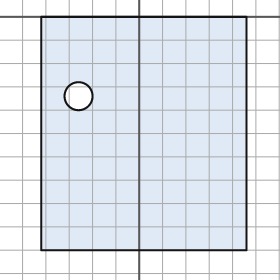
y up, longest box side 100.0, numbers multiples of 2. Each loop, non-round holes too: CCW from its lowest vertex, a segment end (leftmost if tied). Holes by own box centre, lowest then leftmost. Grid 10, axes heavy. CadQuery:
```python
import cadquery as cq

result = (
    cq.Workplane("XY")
    .moveTo(-42.0, -100.0)
    .lineTo(46.0, -100.0)
    .lineTo(46.0, 0.0)
    .lineTo(-42.0, 0.0)
    .close()
    .moveTo(-26.0, -34.0)
    .circle(6.0)
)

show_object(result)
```